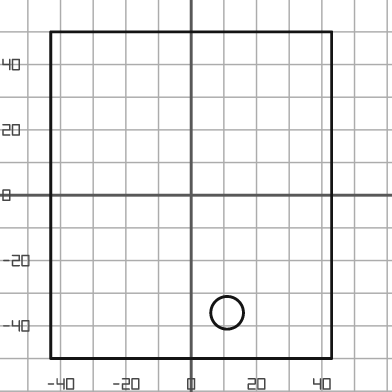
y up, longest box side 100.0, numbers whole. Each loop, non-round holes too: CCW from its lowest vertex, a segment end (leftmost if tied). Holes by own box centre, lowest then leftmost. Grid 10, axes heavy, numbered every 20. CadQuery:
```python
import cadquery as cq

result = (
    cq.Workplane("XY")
    .moveTo(-43.0, -50.0)
    .lineTo(43.0, -50.0)
    .lineTo(43.0, 50.0)
    .lineTo(-43.0, 50.0)
    .close()
    .moveTo(11.0, -36.0)
    .circle(5.0)
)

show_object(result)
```